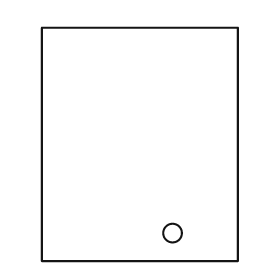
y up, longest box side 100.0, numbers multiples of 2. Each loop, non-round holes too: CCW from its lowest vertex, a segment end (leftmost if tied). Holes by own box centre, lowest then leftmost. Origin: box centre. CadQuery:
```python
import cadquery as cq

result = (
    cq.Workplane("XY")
    .moveTo(-42.0, -50.0)
    .lineTo(42.0, -50.0)
    .lineTo(42.0, 50.0)
    .lineTo(-42.0, 50.0)
    .close()
    .moveTo(14.0, -38.0)
    .circle(4.0)
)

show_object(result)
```